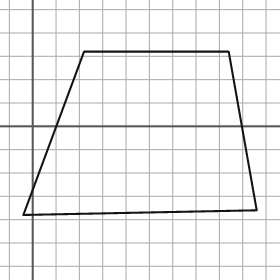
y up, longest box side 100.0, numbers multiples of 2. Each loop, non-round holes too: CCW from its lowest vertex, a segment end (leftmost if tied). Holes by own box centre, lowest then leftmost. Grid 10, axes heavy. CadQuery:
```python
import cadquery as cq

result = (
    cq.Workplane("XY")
    .moveTo(-4.0, -38.0)
    .lineTo(96.0, -36.0)
    .lineTo(84.0, 32.0)
    .lineTo(22.0, 32.0)
    .close()
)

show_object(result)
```